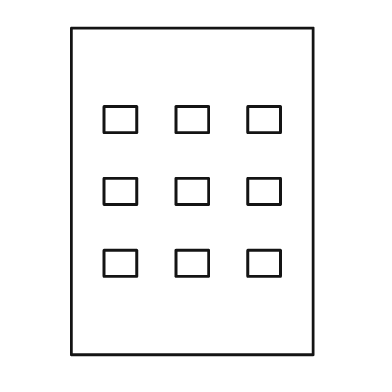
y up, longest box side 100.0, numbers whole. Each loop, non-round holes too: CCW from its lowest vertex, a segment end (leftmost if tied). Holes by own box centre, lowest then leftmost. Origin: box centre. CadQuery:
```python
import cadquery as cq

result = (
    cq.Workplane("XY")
    .moveTo(-37.0, -50.0)
    .lineTo(37.0, -50.0)
    .lineTo(37.0, 50.0)
    .lineTo(-37.0, 50.0)
    .close()
    .moveTo(-27.0, -26.0)
    .lineTo(-17.0, -26.0)
    .lineTo(-17.0, -18.0)
    .lineTo(-27.0, -18.0)
    .close()
    .moveTo(-5.0, -26.0)
    .lineTo(5.0, -26.0)
    .lineTo(5.0, -18.0)
    .lineTo(-5.0, -18.0)
    .close()
    .moveTo(17.0, -26.0)
    .lineTo(27.0, -26.0)
    .lineTo(27.0, -18.0)
    .lineTo(17.0, -18.0)
    .close()
    .moveTo(-27.0, -4.0)
    .lineTo(-17.0, -4.0)
    .lineTo(-17.0, 4.0)
    .lineTo(-27.0, 4.0)
    .close()
    .moveTo(-5.0, -4.0)
    .lineTo(5.0, -4.0)
    .lineTo(5.0, 4.0)
    .lineTo(-5.0, 4.0)
    .close()
    .moveTo(17.0, -4.0)
    .lineTo(27.0, -4.0)
    .lineTo(27.0, 4.0)
    .lineTo(17.0, 4.0)
    .close()
    .moveTo(-27.0, 18.0)
    .lineTo(-17.0, 18.0)
    .lineTo(-17.0, 26.0)
    .lineTo(-27.0, 26.0)
    .close()
    .moveTo(-5.0, 18.0)
    .lineTo(5.0, 18.0)
    .lineTo(5.0, 26.0)
    .lineTo(-5.0, 26.0)
    .close()
    .moveTo(17.0, 18.0)
    .lineTo(27.0, 18.0)
    .lineTo(27.0, 26.0)
    .lineTo(17.0, 26.0)
    .close()
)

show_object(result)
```